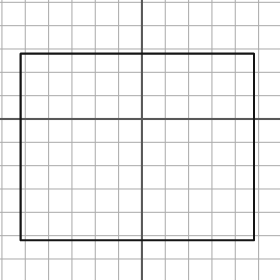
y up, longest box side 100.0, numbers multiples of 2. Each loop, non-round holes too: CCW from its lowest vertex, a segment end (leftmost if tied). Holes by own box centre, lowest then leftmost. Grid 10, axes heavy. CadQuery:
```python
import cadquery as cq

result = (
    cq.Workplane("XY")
    .moveTo(-52.0, -52.0)
    .lineTo(48.0, -52.0)
    .lineTo(48.0, 28.0)
    .lineTo(-52.0, 28.0)
    .close()
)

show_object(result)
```